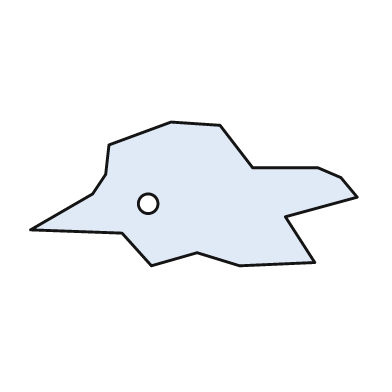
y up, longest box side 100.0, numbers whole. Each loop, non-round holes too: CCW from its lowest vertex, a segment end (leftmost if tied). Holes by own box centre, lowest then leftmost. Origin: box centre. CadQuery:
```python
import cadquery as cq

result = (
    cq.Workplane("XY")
    .moveTo(-13.0, -22.0)
    .lineTo(1.0, -18.0)
    .lineTo(14.0, -22.0)
    .lineTo(37.0, -21.0)
    .lineTo(28.0, -7.0)
    .lineTo(50.0, -1.0)
    .lineTo(45.0, 5.0)
    .lineTo(38.0, 8.0)
    .lineTo(18.0, 8.0)
    .lineTo(8.0, 21.0)
    .lineTo(-7.0, 22.0)
    .lineTo(-26.0, 15.0)
    .lineTo(-27.0, 6.0)
    .lineTo(-31.0, 0.0)
    .lineTo(-50.0, -11.0)
    .lineTo(-22.0, -12.0)
    .close()
    .moveTo(-14.0, -3.0)
    .circle(3.0)
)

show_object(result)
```